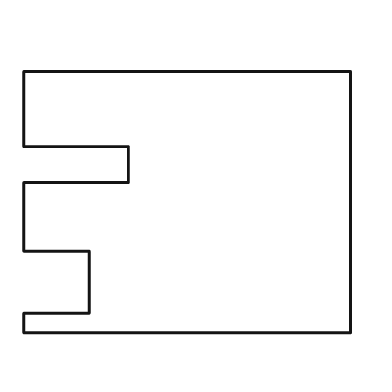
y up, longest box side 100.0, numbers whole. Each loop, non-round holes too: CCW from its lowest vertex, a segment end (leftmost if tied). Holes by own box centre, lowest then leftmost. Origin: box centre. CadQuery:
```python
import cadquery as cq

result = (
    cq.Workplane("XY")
    .moveTo(-50.0, -40.0)
    .lineTo(50.0, -40.0)
    .lineTo(50.0, 40.0)
    .lineTo(-50.0, 40.0)
    .lineTo(-50.0, 17.0)
    .lineTo(-18.0, 17.0)
    .lineTo(-18.0, 6.0)
    .lineTo(-50.0, 6.0)
    .lineTo(-50.0, -15.0)
    .lineTo(-30.0, -15.0)
    .lineTo(-30.0, -34.0)
    .lineTo(-50.0, -34.0)
    .close()
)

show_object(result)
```